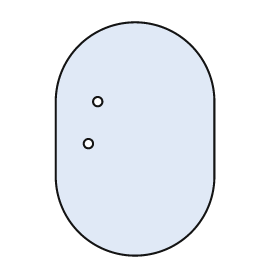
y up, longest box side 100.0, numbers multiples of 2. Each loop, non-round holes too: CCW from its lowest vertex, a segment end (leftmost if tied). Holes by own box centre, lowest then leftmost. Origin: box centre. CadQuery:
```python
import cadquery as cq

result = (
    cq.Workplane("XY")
    .moveTo(-34.0, -16.0)
    .threePointArc((0.0, -50.0), (34.0, -16.0))
    .lineTo(34.0, 16.0)
    .threePointArc((0.0, 50.0), (-34.0, 16.0))
    .close()
    .moveTo(-20.0, -2.0)
    .circle(2.0)
    .moveTo(-16.0, 16.0)
    .circle(2.0)
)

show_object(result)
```